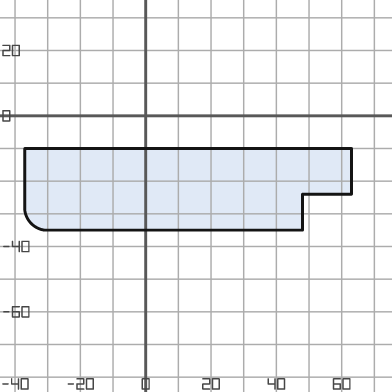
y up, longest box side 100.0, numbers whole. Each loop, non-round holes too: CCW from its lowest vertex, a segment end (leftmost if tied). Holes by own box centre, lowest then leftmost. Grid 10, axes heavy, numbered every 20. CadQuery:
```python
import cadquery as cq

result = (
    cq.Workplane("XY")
    .moveTo(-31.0, -35.0)
    .lineTo(48.0, -35.0)
    .lineTo(48.0, -24.0)
    .lineTo(63.0, -24.0)
    .lineTo(63.0, -10.0)
    .lineTo(-37.0, -10.0)
    .lineTo(-37.0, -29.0)
    .threePointArc((-35.0, -33.0), (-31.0, -35.0))
    .close()
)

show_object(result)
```